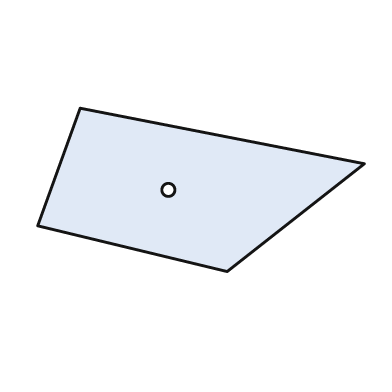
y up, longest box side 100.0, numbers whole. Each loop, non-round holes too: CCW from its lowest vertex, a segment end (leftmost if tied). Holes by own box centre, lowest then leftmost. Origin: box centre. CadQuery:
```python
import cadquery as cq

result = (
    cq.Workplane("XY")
    .moveTo(8.0, -25.0)
    .lineTo(50.0, 8.0)
    .lineTo(-37.0, 25.0)
    .lineTo(-50.0, -11.0)
    .close()
    .moveTo(-10.0, 0.0)
    .circle(2.0)
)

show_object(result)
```